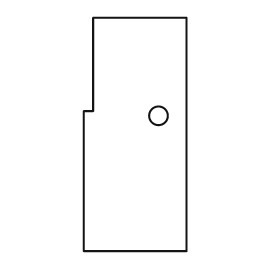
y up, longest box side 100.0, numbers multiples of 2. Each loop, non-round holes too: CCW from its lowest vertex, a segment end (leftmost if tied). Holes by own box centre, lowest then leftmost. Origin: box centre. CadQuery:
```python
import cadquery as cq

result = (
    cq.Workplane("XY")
    .moveTo(-22.0, -50.0)
    .lineTo(22.0, -50.0)
    .lineTo(22.0, 50.0)
    .lineTo(-18.0, 50.0)
    .lineTo(-18.0, 10.0)
    .lineTo(-22.0, 10.0)
    .close()
    .moveTo(10.0, 8.0)
    .circle(4.0)
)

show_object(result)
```